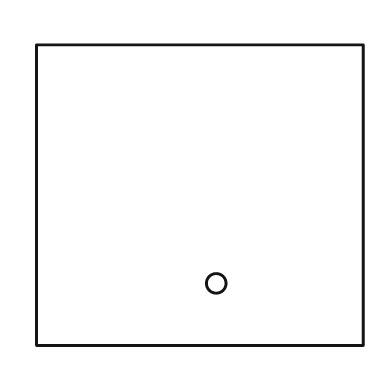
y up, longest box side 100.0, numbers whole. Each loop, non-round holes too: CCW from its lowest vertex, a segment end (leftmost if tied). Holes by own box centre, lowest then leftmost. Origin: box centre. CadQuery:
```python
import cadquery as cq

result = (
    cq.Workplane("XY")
    .moveTo(-50.0, -46.0)
    .lineTo(50.0, -46.0)
    .lineTo(50.0, 46.0)
    .lineTo(-50.0, 46.0)
    .close()
    .moveTo(5.0, -27.0)
    .circle(3.0)
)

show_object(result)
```